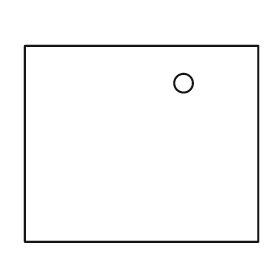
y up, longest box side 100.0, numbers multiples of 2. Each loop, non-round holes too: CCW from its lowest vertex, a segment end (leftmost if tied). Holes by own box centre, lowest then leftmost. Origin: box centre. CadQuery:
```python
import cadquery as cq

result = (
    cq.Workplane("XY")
    .moveTo(-50.0, -42.0)
    .lineTo(50.0, -42.0)
    .lineTo(50.0, 42.0)
    .lineTo(-50.0, 42.0)
    .close()
    .moveTo(18.0, 26.0)
    .circle(4.0)
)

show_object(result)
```